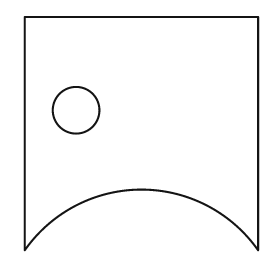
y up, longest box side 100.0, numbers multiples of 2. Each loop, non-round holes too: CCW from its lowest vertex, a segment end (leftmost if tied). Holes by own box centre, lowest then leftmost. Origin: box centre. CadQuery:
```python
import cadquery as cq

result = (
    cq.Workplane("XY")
    .moveTo(-50.0, -50.0)
    .threePointArc((0.0, -24.0), (50.0, -50.0))
    .lineTo(50.0, 50.0)
    .lineTo(-50.0, 50.0)
    .close()
    .moveTo(-28.0, 10.0)
    .circle(10.0)
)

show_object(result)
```